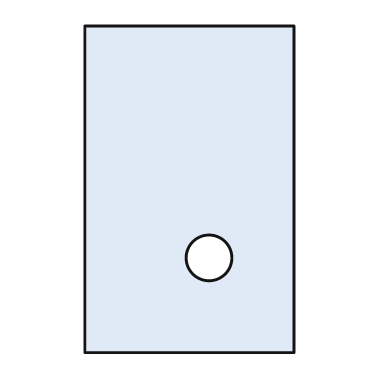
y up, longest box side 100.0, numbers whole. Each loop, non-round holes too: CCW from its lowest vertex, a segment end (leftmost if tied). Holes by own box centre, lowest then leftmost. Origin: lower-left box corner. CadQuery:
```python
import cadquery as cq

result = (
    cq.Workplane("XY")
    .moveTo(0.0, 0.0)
    .lineTo(64.0, 0.0)
    .lineTo(64.0, 100.0)
    .lineTo(0.0, 100.0)
    .close()
    .moveTo(38.0, 29.0)
    .circle(7.0)
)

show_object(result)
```